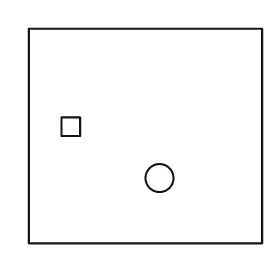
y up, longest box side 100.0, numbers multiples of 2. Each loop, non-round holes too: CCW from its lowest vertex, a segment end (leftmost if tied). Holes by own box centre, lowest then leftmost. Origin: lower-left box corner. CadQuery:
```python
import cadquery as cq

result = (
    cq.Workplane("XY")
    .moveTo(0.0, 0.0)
    .lineTo(100.0, 0.0)
    .lineTo(100.0, 92.0)
    .lineTo(0.0, 92.0)
    .close()
    .moveTo(56.0, 28.0)
    .circle(6.0)
    .moveTo(14.0, 46.0)
    .lineTo(22.0, 46.0)
    .lineTo(22.0, 54.0)
    .lineTo(14.0, 54.0)
    .close()
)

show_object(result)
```